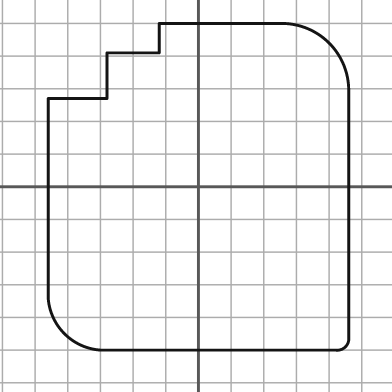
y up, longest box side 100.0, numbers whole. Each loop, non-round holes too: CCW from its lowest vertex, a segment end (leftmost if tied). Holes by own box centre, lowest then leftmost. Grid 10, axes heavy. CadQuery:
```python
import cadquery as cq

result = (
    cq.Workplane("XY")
    .moveTo(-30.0, -50.0)
    .lineTo(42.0, -50.0)
    .threePointArc((45.0, -49.0), (46.0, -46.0))
    .lineTo(46.0, 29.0)
    .threePointArc((40.0, 44.0), (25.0, 50.0))
    .lineTo(-12.0, 50.0)
    .lineTo(-12.0, 41.0)
    .lineTo(-28.0, 41.0)
    .lineTo(-28.0, 27.0)
    .lineTo(-46.0, 27.0)
    .lineTo(-46.0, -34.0)
    .threePointArc((-41.0, -45.0), (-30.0, -50.0))
    .close()
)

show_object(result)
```